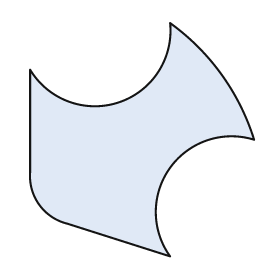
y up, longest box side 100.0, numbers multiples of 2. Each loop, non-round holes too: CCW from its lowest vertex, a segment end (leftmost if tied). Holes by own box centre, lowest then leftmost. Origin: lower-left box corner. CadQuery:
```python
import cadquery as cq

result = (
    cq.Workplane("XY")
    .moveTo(60.0, 0.0)
    .threePointArc((60.0, 38.0), (96.0, 50.0))
    .threePointArc((82.0, 78.0), (60.0, 100.0))
    .threePointArc((38.0, 66.0), (0.0, 80.0))
    .lineTo(0.0, 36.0)
    .threePointArc((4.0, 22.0), (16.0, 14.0))
    .close()
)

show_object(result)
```